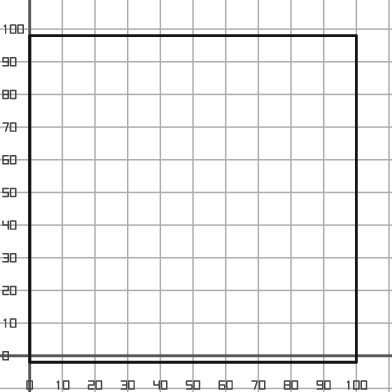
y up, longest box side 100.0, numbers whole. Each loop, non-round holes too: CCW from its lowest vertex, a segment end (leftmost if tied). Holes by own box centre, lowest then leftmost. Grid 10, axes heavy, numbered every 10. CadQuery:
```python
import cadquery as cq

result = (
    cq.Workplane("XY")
    .moveTo(0.0, -2.0)
    .lineTo(100.0, -2.0)
    .lineTo(100.0, 98.0)
    .lineTo(0.0, 98.0)
    .close()
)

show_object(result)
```